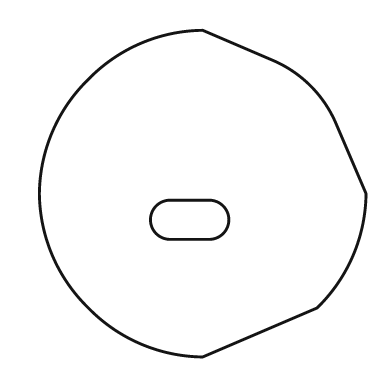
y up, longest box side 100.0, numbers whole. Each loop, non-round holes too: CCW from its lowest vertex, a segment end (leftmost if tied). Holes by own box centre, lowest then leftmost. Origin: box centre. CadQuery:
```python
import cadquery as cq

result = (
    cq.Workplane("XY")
    .moveTo(0.0, -50.0)
    .lineTo(35.0, -35.0)
    .threePointArc((46.0, -19.0), (50.0, 0.0))
    .lineTo(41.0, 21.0)
    .threePointArc((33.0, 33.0), (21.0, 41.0))
    .lineTo(0.0, 50.0)
    .threePointArc((-19.0, 46.0), (-35.0, 35.0))
    .threePointArc((-46.0, 19.0), (-50.0, 0.0))
    .threePointArc((-46.0, -19.0), (-35.0, -35.0))
    .threePointArc((-19.0, -46.0), (0.0, -50.0))
    .close()
    .moveTo(-10.0, -14.0)
    .lineTo(2.0, -14.0)
    .threePointArc((8.0, -8.0), (2.0, -2.0))
    .lineTo(-10.0, -2.0)
    .threePointArc((-16.0, -8.0), (-10.0, -14.0))
    .close()
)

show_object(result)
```